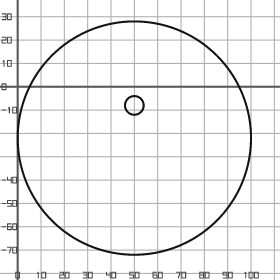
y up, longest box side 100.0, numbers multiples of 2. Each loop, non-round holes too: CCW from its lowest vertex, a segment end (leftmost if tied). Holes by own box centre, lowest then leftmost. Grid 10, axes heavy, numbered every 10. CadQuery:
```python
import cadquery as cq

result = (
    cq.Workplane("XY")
    .moveTo(50.0, -22.0)
    .circle(50.0)
    .moveTo(50.0, -8.0)
    .circle(4.0)
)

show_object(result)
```